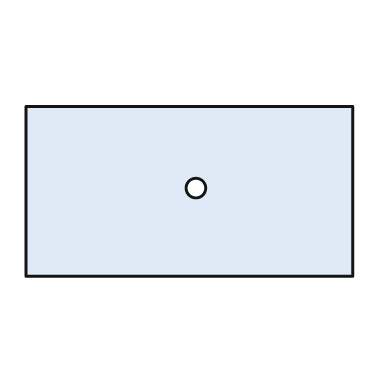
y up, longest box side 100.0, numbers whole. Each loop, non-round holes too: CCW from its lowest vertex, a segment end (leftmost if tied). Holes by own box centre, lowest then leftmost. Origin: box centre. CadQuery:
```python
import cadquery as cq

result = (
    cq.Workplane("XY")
    .moveTo(-50.0, -26.0)
    .lineTo(50.0, -26.0)
    .lineTo(50.0, 26.0)
    .lineTo(-50.0, 26.0)
    .close()
    .moveTo(2.0, 1.0)
    .circle(3.0)
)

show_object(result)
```